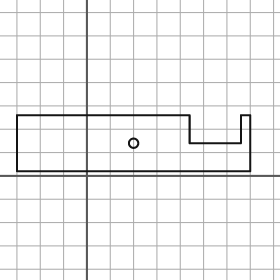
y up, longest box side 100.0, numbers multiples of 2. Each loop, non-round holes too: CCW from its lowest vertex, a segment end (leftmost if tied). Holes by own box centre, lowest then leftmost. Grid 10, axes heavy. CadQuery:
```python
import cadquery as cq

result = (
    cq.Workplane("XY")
    .moveTo(-30.0, 2.0)
    .lineTo(70.0, 2.0)
    .lineTo(70.0, 26.0)
    .lineTo(66.0, 26.0)
    .lineTo(66.0, 14.0)
    .lineTo(44.0, 14.0)
    .lineTo(44.0, 26.0)
    .lineTo(-30.0, 26.0)
    .close()
    .moveTo(20.0, 14.0)
    .circle(2.0)
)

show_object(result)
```